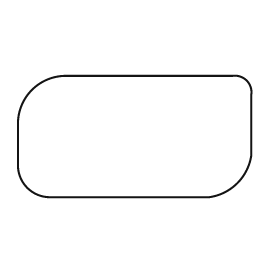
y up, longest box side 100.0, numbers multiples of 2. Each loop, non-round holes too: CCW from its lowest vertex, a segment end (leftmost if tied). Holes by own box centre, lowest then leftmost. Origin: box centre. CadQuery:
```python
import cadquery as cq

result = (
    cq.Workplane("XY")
    .moveTo(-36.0, -26.0)
    .lineTo(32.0, -26.0)
    .threePointArc((44.0, -20.0), (50.0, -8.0))
    .lineTo(50.0, 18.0)
    .threePointArc((48.0, 24.0), (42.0, 26.0))
    .lineTo(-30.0, 26.0)
    .threePointArc((-44.0, 20.0), (-50.0, 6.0))
    .lineTo(-50.0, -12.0)
    .threePointArc((-46.0, -22.0), (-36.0, -26.0))
    .close()
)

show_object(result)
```